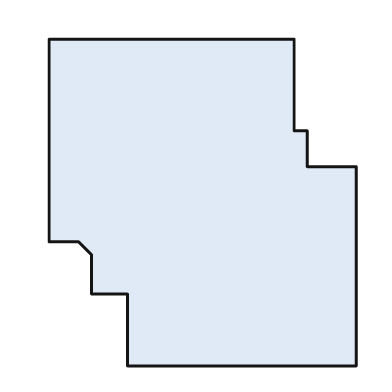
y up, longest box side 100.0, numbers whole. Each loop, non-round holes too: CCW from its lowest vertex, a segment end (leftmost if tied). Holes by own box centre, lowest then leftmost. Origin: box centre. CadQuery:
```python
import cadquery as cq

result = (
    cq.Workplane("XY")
    .moveTo(-23.0, -50.0)
    .lineTo(47.0, -50.0)
    .lineTo(47.0, 11.0)
    .lineTo(32.0, 11.0)
    .lineTo(32.0, 22.0)
    .lineTo(28.0, 22.0)
    .lineTo(28.0, 50.0)
    .lineTo(-47.0, 50.0)
    .lineTo(-47.0, -12.0)
    .lineTo(-38.0, -12.0)
    .lineTo(-34.0, -16.0)
    .lineTo(-34.0, -28.0)
    .lineTo(-23.0, -28.0)
    .close()
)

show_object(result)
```